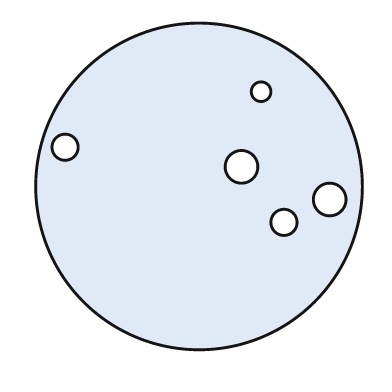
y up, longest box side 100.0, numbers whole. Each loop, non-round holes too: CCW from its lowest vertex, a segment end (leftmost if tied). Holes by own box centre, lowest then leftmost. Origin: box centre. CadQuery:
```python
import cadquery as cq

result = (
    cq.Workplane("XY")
    .moveTo(0.0, 0.0)
    .circle(50.0)
    .moveTo(26.0, -11.0)
    .circle(4.0)
    .moveTo(40.0, -4.0)
    .circle(5.0)
    .moveTo(13.0, 6.0)
    .circle(5.0)
    .moveTo(-41.0, 12.0)
    .circle(4.0)
    .moveTo(19.0, 29.0)
    .circle(3.0)
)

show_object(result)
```